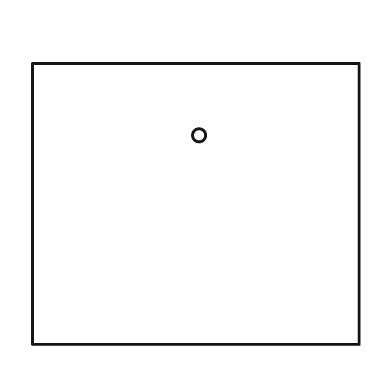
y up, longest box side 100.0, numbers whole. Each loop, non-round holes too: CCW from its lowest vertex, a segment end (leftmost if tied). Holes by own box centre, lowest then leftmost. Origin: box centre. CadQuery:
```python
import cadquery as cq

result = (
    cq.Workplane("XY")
    .moveTo(-50.0, -43.0)
    .lineTo(50.0, -43.0)
    .lineTo(50.0, 43.0)
    .lineTo(-50.0, 43.0)
    .close()
    .moveTo(1.0, 21.0)
    .circle(2.0)
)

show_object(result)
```